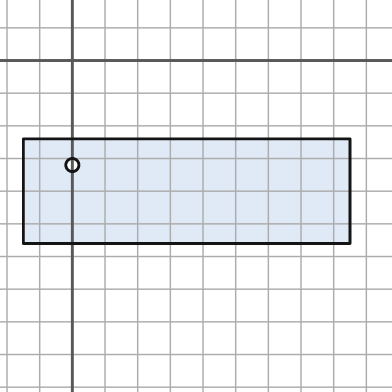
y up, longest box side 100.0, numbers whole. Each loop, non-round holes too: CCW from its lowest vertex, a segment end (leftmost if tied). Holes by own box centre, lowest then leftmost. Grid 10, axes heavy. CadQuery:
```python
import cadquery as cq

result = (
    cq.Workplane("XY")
    .moveTo(-15.0, -56.0)
    .lineTo(85.0, -56.0)
    .lineTo(85.0, -24.0)
    .lineTo(-15.0, -24.0)
    .close()
    .moveTo(0.0, -32.0)
    .circle(2.0)
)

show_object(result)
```